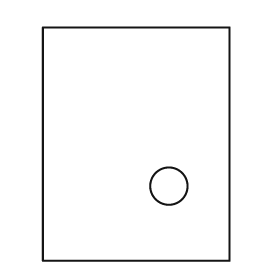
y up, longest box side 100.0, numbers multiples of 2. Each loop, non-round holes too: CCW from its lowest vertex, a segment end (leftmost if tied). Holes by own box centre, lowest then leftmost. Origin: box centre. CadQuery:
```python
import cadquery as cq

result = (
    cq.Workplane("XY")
    .moveTo(-40.0, -50.0)
    .lineTo(40.0, -50.0)
    .lineTo(40.0, 50.0)
    .lineTo(-40.0, 50.0)
    .close()
    .moveTo(14.0, -18.0)
    .circle(8.0)
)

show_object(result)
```